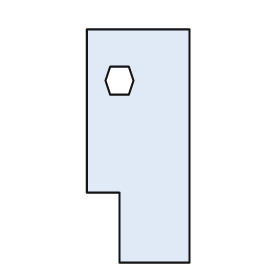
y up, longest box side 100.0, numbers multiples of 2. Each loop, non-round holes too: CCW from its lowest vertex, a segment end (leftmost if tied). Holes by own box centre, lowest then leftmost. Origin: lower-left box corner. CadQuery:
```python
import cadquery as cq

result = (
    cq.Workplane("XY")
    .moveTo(14.0, 0.0)
    .lineTo(44.0, 0.0)
    .lineTo(44.0, 100.0)
    .lineTo(0.0, 100.0)
    .lineTo(0.0, 30.0)
    .lineTo(14.0, 30.0)
    .close()
    .moveTo(10.0, 72.0)
    .lineTo(18.0, 72.0)
    .lineTo(20.0, 78.0)
    .lineTo(18.0, 84.0)
    .lineTo(10.0, 84.0)
    .lineTo(8.0, 78.0)
    .close()
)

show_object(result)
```